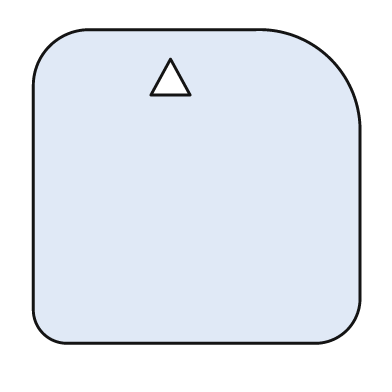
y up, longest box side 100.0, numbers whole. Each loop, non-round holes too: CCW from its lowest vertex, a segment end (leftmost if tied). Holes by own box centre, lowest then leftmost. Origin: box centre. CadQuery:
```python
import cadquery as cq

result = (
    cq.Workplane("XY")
    .moveTo(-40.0, -48.0)
    .lineTo(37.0, -48.0)
    .threePointArc((46.0, -44.0), (50.0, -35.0))
    .lineTo(50.0, 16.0)
    .threePointArc((41.0, 39.0), (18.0, 48.0))
    .lineTo(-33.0, 48.0)
    .threePointArc((-45.0, 43.0), (-50.0, 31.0))
    .lineTo(-50.0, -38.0)
    .threePointArc((-47.0, -45.0), (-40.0, -48.0))
    .close()
    .moveTo(-14.0, 28.0)
    .lineTo(-2.0, 28.0)
    .lineTo(-8.0, 39.0)
    .close()
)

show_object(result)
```